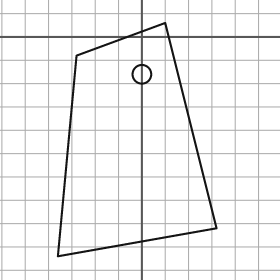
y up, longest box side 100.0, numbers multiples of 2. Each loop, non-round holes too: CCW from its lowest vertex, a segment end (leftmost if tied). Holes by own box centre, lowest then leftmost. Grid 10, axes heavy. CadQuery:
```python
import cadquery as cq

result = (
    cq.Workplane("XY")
    .moveTo(-36.0, -94.0)
    .lineTo(32.0, -82.0)
    .lineTo(10.0, 6.0)
    .lineTo(-28.0, -8.0)
    .close()
    .moveTo(0.0, -16.0)
    .circle(4.0)
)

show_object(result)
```